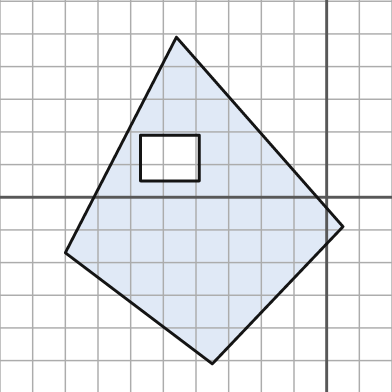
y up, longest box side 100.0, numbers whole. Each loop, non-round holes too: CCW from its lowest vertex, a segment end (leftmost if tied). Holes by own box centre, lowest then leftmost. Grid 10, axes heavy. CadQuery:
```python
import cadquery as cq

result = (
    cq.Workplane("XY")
    .moveTo(-35.0, -51.0)
    .lineTo(5.0, -9.0)
    .lineTo(-46.0, 49.0)
    .lineTo(-80.0, -17.0)
    .close()
    .moveTo(-57.0, 5.0)
    .lineTo(-39.0, 5.0)
    .lineTo(-39.0, 19.0)
    .lineTo(-57.0, 19.0)
    .close()
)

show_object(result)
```